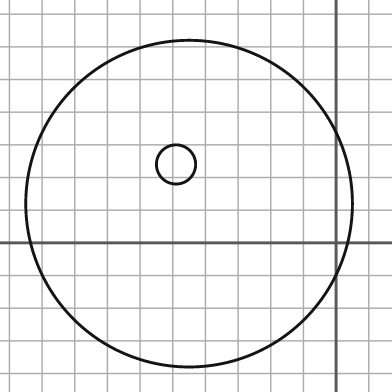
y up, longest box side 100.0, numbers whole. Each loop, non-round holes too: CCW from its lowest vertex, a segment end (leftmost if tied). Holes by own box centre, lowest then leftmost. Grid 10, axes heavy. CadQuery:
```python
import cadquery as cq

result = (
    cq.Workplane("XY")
    .moveTo(-45.0, 12.0)
    .circle(50.0)
    .moveTo(-49.0, 24.0)
    .circle(6.0)
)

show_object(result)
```